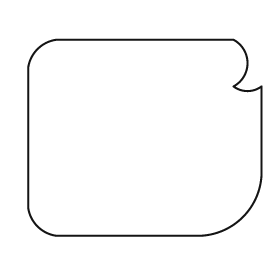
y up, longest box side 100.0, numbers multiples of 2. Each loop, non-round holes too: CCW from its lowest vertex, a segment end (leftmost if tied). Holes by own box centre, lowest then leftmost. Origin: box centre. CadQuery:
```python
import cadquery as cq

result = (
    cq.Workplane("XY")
    .moveTo(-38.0, -42.0)
    .lineTo(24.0, -42.0)
    .threePointArc((42.0, -34.0), (50.0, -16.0))
    .lineTo(50.0, 22.0)
    .threePointArc((44.0, 20.0), (38.0, 22.0))
    .threePointArc((44.0, 32.0), (38.0, 42.0))
    .lineTo(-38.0, 42.0)
    .threePointArc((-46.0, 38.0), (-50.0, 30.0))
    .lineTo(-50.0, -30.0)
    .threePointArc((-46.0, -38.0), (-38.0, -42.0))
    .close()
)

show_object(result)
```